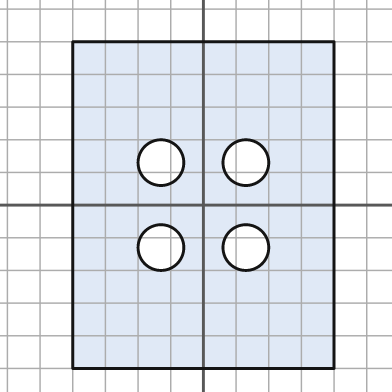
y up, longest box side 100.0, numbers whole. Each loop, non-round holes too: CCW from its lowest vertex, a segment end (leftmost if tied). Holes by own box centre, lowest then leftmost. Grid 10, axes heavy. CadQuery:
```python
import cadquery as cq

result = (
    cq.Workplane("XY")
    .moveTo(-40.0, -50.0)
    .lineTo(40.0, -50.0)
    .lineTo(40.0, 50.0)
    .lineTo(-40.0, 50.0)
    .close()
    .moveTo(-13.0, -13.0)
    .circle(7.0)
    .moveTo(13.0, -13.0)
    .circle(7.0)
    .moveTo(-13.0, 13.0)
    .circle(7.0)
    .moveTo(13.0, 13.0)
    .circle(7.0)
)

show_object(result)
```